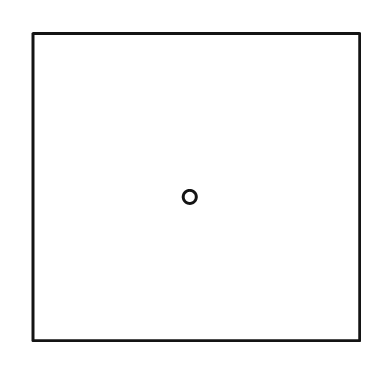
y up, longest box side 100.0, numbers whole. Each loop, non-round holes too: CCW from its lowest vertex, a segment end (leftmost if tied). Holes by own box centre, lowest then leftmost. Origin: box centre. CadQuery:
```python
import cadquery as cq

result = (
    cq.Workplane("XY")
    .moveTo(-50.0, -47.0)
    .lineTo(50.0, -47.0)
    .lineTo(50.0, 47.0)
    .lineTo(-50.0, 47.0)
    .close()
    .moveTo(-2.0, -3.0)
    .circle(2.0)
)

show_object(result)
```